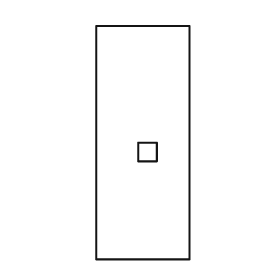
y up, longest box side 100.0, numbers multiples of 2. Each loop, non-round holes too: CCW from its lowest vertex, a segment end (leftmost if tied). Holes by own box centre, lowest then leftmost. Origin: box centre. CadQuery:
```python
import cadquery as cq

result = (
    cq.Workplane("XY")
    .moveTo(-20.0, -50.0)
    .lineTo(20.0, -50.0)
    .lineTo(20.0, 50.0)
    .lineTo(-20.0, 50.0)
    .close()
    .moveTo(-2.0, -8.0)
    .lineTo(6.0, -8.0)
    .lineTo(6.0, 0.0)
    .lineTo(-2.0, 0.0)
    .close()
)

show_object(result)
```